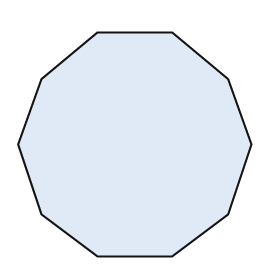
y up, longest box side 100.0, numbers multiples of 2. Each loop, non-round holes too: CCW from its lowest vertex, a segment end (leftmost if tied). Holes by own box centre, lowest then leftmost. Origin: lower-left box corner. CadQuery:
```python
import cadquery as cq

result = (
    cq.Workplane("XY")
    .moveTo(34.0, 0.0)
    .lineTo(66.0, 0.0)
    .lineTo(90.0, 18.0)
    .lineTo(100.0, 48.0)
    .lineTo(90.0, 76.0)
    .lineTo(66.0, 96.0)
    .lineTo(34.0, 96.0)
    .lineTo(10.0, 76.0)
    .lineTo(0.0, 48.0)
    .lineTo(10.0, 18.0)
    .close()
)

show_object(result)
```